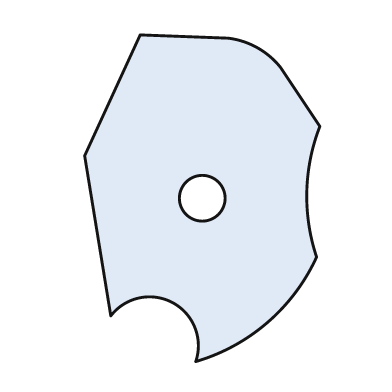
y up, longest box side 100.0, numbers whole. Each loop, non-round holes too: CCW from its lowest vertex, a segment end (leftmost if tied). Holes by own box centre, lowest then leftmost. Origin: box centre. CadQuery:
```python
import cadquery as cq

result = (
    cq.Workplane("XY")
    .moveTo(-2.0, -50.0)
    .threePointArc((20.0, -38.0), (35.0, -18.0))
    .threePointArc((32.0, 2.0), (36.0, 22.0))
    .lineTo(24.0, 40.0)
    .threePointArc((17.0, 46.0), (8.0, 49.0))
    .lineTo(-19.0, 50.0)
    .lineTo(-36.0, 13.0)
    .lineTo(-28.0, -36.0)
    .threePointArc((-9.0, -32.0), (-2.0, -50.0))
    .close()
    .moveTo(0.0, 0.0)
    .circle(7.0)
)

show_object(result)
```